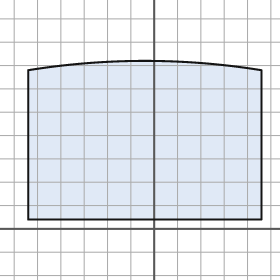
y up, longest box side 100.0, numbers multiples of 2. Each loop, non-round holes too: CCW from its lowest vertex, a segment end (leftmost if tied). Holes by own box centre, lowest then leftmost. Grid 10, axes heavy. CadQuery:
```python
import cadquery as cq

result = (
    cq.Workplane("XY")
    .moveTo(-54.0, 4.0)
    .lineTo(46.0, 4.0)
    .lineTo(46.0, 68.0)
    .threePointArc((-4.0, 72.0), (-54.0, 68.0))
    .close()
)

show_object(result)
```